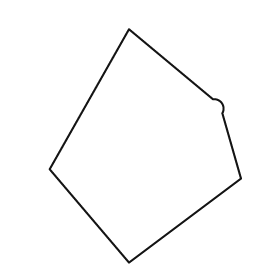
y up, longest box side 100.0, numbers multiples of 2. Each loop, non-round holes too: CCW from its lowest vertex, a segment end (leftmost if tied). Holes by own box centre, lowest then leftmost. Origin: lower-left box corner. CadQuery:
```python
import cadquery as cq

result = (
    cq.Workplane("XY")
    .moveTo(34.0, 0.0)
    .lineTo(82.0, 36.0)
    .lineTo(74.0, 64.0)
    .threePointArc((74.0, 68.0), (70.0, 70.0))
    .lineTo(34.0, 100.0)
    .lineTo(0.0, 40.0)
    .close()
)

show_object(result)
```